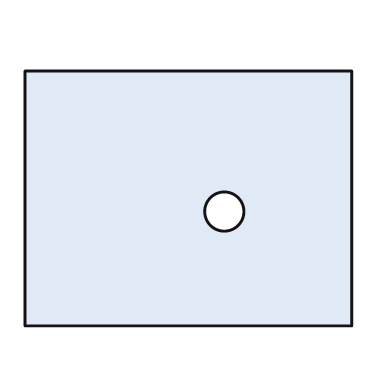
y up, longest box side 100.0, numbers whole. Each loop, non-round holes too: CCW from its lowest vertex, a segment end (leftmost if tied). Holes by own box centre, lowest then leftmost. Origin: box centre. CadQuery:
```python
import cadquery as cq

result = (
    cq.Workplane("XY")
    .moveTo(-50.0, -39.0)
    .lineTo(50.0, -39.0)
    .lineTo(50.0, 39.0)
    .lineTo(-50.0, 39.0)
    .close()
    .moveTo(11.0, -4.0)
    .circle(6.0)
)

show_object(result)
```